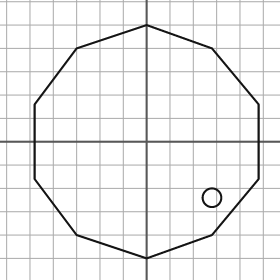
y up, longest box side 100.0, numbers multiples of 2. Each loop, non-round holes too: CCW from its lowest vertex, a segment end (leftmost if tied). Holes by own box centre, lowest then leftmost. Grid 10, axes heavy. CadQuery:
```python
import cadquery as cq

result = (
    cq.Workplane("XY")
    .moveTo(0.0, -50.0)
    .lineTo(28.0, -40.0)
    .lineTo(48.0, -16.0)
    .lineTo(48.0, 16.0)
    .lineTo(28.0, 40.0)
    .lineTo(0.0, 50.0)
    .lineTo(-30.0, 40.0)
    .lineTo(-48.0, 16.0)
    .lineTo(-48.0, -16.0)
    .lineTo(-30.0, -40.0)
    .close()
    .moveTo(28.0, -24.0)
    .circle(4.0)
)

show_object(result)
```